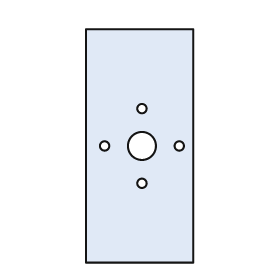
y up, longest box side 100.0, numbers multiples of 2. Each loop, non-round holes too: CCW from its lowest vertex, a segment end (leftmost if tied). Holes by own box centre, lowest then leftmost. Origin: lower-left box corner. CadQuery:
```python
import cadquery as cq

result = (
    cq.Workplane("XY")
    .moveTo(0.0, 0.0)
    .lineTo(46.0, 0.0)
    .lineTo(46.0, 100.0)
    .lineTo(0.0, 100.0)
    .close()
    .moveTo(24.0, 34.0)
    .circle(2.0)
    .moveTo(8.0, 50.0)
    .circle(2.0)
    .moveTo(24.0, 50.0)
    .circle(6.0)
    .moveTo(40.0, 50.0)
    .circle(2.0)
    .moveTo(24.0, 66.0)
    .circle(2.0)
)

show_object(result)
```